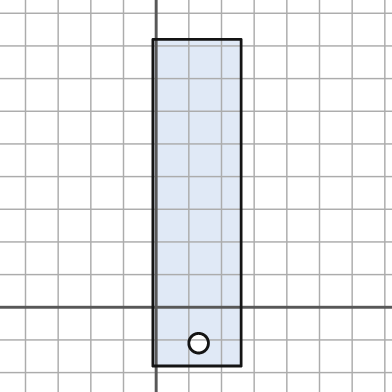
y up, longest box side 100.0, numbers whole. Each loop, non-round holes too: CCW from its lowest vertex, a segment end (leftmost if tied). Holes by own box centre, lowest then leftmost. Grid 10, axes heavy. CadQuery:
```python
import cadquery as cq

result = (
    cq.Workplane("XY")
    .moveTo(-1.0, -18.0)
    .lineTo(26.0, -18.0)
    .lineTo(26.0, 82.0)
    .lineTo(-1.0, 82.0)
    .close()
    .moveTo(13.0, -11.0)
    .circle(3.0)
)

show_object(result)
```